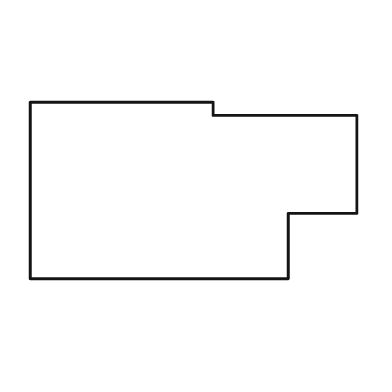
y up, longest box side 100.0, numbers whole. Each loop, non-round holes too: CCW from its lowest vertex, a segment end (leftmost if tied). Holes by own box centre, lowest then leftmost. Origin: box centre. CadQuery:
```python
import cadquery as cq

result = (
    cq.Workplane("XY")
    .moveTo(-50.0, -27.0)
    .lineTo(29.0, -27.0)
    .lineTo(29.0, -7.0)
    .lineTo(50.0, -7.0)
    .lineTo(50.0, 23.0)
    .lineTo(6.0, 23.0)
    .lineTo(6.0, 27.0)
    .lineTo(-50.0, 27.0)
    .close()
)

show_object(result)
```